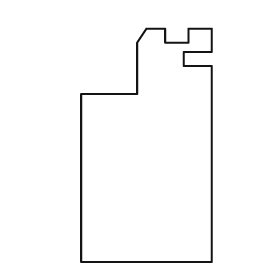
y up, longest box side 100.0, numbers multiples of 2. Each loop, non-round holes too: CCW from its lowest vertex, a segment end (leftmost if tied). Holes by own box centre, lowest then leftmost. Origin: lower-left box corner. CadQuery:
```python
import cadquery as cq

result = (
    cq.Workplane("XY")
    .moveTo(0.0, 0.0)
    .lineTo(56.0, 0.0)
    .lineTo(56.0, 84.0)
    .lineTo(44.0, 84.0)
    .lineTo(44.0, 90.0)
    .lineTo(56.0, 90.0)
    .lineTo(56.0, 100.0)
    .lineTo(46.0, 100.0)
    .lineTo(46.0, 94.0)
    .lineTo(36.0, 94.0)
    .lineTo(36.0, 100.0)
    .lineTo(28.0, 100.0)
    .lineTo(24.0, 94.0)
    .lineTo(24.0, 72.0)
    .lineTo(0.0, 72.0)
    .close()
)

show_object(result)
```